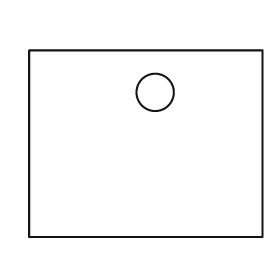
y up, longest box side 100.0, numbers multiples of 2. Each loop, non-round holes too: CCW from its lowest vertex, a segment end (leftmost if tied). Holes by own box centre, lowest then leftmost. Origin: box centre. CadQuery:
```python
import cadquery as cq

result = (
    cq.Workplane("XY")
    .moveTo(-50.0, -40.0)
    .lineTo(50.0, -40.0)
    .lineTo(50.0, 40.0)
    .lineTo(-50.0, 40.0)
    .close()
    .moveTo(4.0, 22.0)
    .circle(8.0)
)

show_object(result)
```